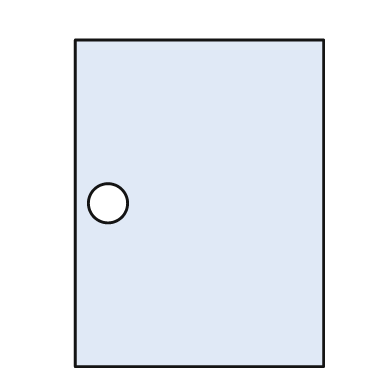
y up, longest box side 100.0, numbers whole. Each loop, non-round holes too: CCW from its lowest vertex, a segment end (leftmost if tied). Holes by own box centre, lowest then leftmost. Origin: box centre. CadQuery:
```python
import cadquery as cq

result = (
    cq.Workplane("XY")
    .moveTo(-38.0, -50.0)
    .lineTo(38.0, -50.0)
    .lineTo(38.0, 50.0)
    .lineTo(-38.0, 50.0)
    .close()
    .moveTo(-28.0, 0.0)
    .circle(6.0)
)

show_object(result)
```